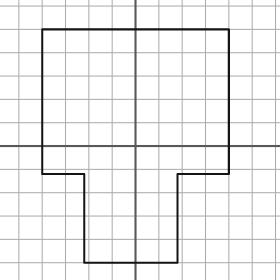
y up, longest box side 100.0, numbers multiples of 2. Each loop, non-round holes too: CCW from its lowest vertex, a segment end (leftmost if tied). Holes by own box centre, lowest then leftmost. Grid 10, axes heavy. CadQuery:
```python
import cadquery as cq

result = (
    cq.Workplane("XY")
    .moveTo(-22.0, -50.0)
    .lineTo(18.0, -50.0)
    .lineTo(18.0, -12.0)
    .lineTo(40.0, -12.0)
    .lineTo(40.0, 50.0)
    .lineTo(-40.0, 50.0)
    .lineTo(-40.0, -12.0)
    .lineTo(-22.0, -12.0)
    .close()
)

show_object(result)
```